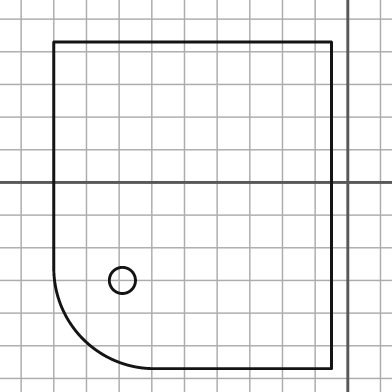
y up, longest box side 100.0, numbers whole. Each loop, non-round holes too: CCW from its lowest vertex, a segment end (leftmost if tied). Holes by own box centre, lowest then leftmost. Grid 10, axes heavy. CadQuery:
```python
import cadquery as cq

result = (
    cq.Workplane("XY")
    .moveTo(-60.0, -57.0)
    .lineTo(-5.0, -57.0)
    .lineTo(-5.0, 43.0)
    .lineTo(-90.0, 43.0)
    .lineTo(-90.0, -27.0)
    .threePointArc((-81.0, -48.0), (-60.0, -57.0))
    .close()
    .moveTo(-69.0, -30.0)
    .circle(4.0)
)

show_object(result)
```